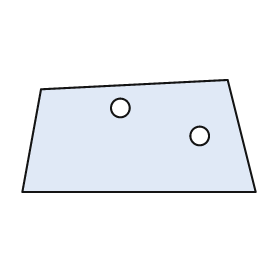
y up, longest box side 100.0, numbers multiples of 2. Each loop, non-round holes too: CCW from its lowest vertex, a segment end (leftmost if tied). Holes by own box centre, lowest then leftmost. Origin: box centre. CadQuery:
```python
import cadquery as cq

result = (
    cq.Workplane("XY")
    .moveTo(-50.0, -24.0)
    .lineTo(50.0, -24.0)
    .lineTo(38.0, 24.0)
    .lineTo(-42.0, 20.0)
    .close()
    .moveTo(26.0, 0.0)
    .circle(4.0)
    .moveTo(-8.0, 12.0)
    .circle(4.0)
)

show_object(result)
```